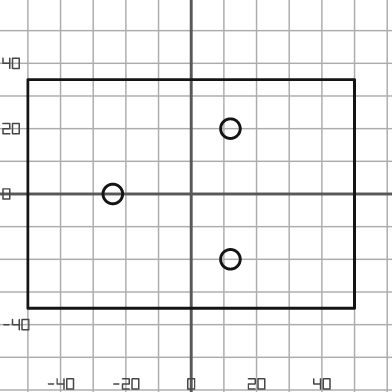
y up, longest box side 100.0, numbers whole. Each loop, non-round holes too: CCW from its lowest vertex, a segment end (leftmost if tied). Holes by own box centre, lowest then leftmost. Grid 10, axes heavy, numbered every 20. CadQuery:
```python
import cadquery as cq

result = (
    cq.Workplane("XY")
    .moveTo(-50.0, -35.0)
    .lineTo(50.0, -35.0)
    .lineTo(50.0, 35.0)
    .lineTo(-50.0, 35.0)
    .close()
    .moveTo(12.0, -20.0)
    .circle(3.0)
    .moveTo(-24.0, 0.0)
    .circle(3.0)
    .moveTo(12.0, 20.0)
    .circle(3.0)
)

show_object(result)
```